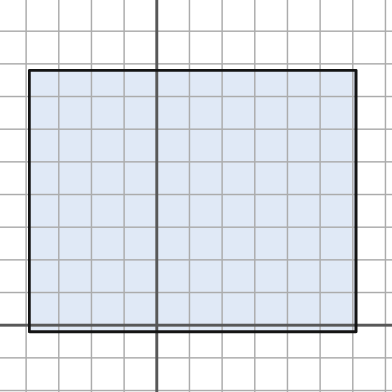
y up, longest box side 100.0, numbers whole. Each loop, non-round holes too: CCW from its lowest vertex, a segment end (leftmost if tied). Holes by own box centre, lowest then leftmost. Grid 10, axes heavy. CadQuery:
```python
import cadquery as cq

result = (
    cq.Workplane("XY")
    .moveTo(-39.0, -2.0)
    .lineTo(61.0, -2.0)
    .lineTo(61.0, 78.0)
    .lineTo(-39.0, 78.0)
    .close()
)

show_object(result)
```